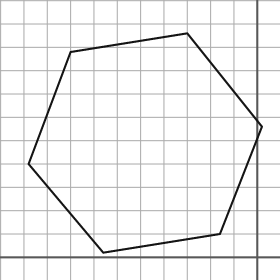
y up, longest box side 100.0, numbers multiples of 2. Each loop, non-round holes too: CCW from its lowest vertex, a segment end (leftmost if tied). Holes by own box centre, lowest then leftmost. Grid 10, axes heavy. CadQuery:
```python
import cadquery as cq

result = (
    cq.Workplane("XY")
    .moveTo(-66.0, 2.0)
    .lineTo(-16.0, 10.0)
    .lineTo(2.0, 56.0)
    .lineTo(-30.0, 96.0)
    .lineTo(-80.0, 88.0)
    .lineTo(-98.0, 40.0)
    .close()
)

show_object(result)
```